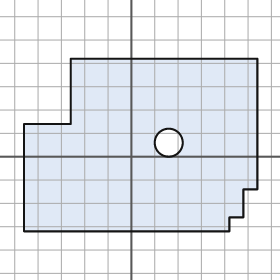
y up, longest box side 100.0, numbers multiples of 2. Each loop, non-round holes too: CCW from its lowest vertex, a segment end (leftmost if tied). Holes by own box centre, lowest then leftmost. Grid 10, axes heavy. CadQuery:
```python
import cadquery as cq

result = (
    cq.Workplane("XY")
    .moveTo(-46.0, -32.0)
    .lineTo(42.0, -32.0)
    .lineTo(42.0, -26.0)
    .lineTo(48.0, -26.0)
    .lineTo(48.0, -14.0)
    .lineTo(54.0, -14.0)
    .lineTo(54.0, 42.0)
    .lineTo(-26.0, 42.0)
    .lineTo(-26.0, 14.0)
    .lineTo(-46.0, 14.0)
    .close()
    .moveTo(16.0, 6.0)
    .circle(6.0)
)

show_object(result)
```